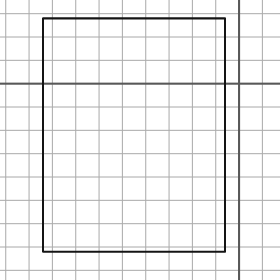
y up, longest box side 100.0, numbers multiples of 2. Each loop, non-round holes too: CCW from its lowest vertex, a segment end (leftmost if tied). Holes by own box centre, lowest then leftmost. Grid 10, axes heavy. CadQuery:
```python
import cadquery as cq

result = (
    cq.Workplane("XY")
    .moveTo(-84.0, -72.0)
    .lineTo(-6.0, -72.0)
    .lineTo(-6.0, 28.0)
    .lineTo(-84.0, 28.0)
    .close()
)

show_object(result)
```